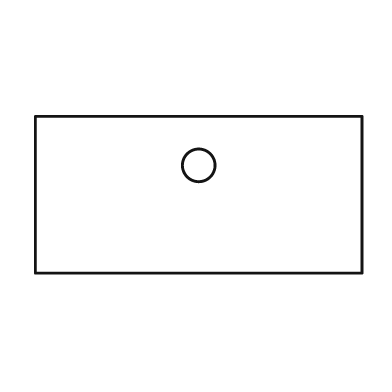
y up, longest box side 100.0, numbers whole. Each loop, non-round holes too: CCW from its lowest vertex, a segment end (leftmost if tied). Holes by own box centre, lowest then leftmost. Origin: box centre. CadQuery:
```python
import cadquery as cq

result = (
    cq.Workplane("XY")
    .moveTo(-50.0, -24.0)
    .lineTo(50.0, -24.0)
    .lineTo(50.0, 24.0)
    .lineTo(-50.0, 24.0)
    .close()
    .moveTo(0.0, 9.0)
    .circle(5.0)
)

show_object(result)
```